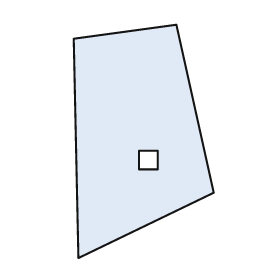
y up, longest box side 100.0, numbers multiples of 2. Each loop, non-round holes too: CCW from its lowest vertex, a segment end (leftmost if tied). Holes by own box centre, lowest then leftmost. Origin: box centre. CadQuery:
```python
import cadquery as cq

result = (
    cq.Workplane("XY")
    .moveTo(-28.0, -50.0)
    .lineTo(30.0, -22.0)
    .lineTo(14.0, 50.0)
    .lineTo(-30.0, 44.0)
    .close()
    .moveTo(-2.0, -12.0)
    .lineTo(6.0, -12.0)
    .lineTo(6.0, -4.0)
    .lineTo(-2.0, -4.0)
    .close()
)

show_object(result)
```